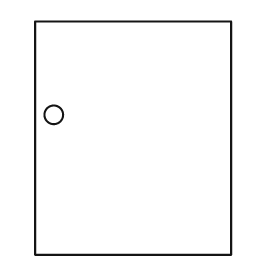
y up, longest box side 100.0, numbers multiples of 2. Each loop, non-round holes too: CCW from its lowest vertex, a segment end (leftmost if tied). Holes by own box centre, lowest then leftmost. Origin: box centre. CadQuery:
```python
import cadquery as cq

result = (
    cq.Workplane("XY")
    .moveTo(-42.0, -50.0)
    .lineTo(42.0, -50.0)
    .lineTo(42.0, 50.0)
    .lineTo(-42.0, 50.0)
    .close()
    .moveTo(-34.0, 10.0)
    .circle(4.0)
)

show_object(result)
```